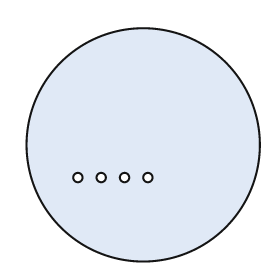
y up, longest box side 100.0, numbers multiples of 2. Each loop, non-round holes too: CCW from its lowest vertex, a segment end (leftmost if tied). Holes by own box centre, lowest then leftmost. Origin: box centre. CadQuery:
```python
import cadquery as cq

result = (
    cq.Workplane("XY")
    .moveTo(0.0, 0.0)
    .circle(50.0)
    .moveTo(-28.0, -14.0)
    .circle(2.0)
    .moveTo(-18.0, -14.0)
    .circle(2.0)
    .moveTo(-8.0, -14.0)
    .circle(2.0)
    .moveTo(2.0, -14.0)
    .circle(2.0)
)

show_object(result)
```